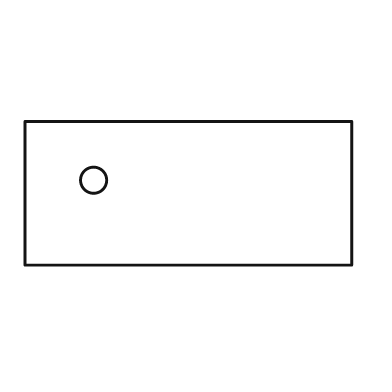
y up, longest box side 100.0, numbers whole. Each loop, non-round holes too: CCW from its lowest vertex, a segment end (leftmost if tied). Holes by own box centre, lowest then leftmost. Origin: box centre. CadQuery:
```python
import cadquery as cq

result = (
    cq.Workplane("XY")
    .moveTo(-50.0, -22.0)
    .lineTo(50.0, -22.0)
    .lineTo(50.0, 22.0)
    .lineTo(-50.0, 22.0)
    .close()
    .moveTo(-29.0, 4.0)
    .circle(4.0)
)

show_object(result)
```